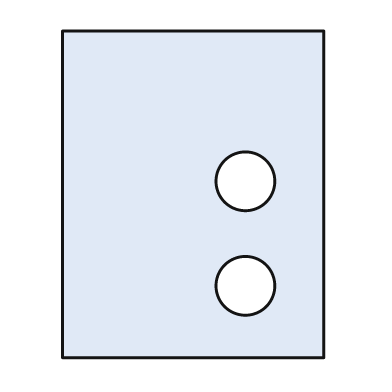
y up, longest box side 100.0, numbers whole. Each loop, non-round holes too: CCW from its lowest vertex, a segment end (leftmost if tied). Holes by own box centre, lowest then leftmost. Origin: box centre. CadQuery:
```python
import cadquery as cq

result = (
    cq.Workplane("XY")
    .moveTo(-40.0, -50.0)
    .lineTo(40.0, -50.0)
    .lineTo(40.0, 50.0)
    .lineTo(-40.0, 50.0)
    .close()
    .moveTo(16.0, -28.0)
    .circle(9.0)
    .moveTo(16.0, 4.0)
    .circle(9.0)
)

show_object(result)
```